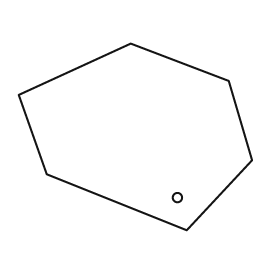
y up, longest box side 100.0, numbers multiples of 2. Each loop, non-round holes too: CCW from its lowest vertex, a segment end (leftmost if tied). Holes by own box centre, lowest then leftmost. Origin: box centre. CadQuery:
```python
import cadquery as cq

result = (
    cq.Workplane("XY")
    .moveTo(22.0, -40.0)
    .lineTo(50.0, -10.0)
    .lineTo(40.0, 24.0)
    .lineTo(-2.0, 40.0)
    .lineTo(-50.0, 18.0)
    .lineTo(-38.0, -16.0)
    .close()
    .moveTo(18.0, -26.0)
    .circle(2.0)
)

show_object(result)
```